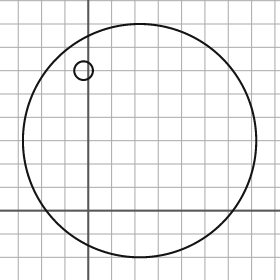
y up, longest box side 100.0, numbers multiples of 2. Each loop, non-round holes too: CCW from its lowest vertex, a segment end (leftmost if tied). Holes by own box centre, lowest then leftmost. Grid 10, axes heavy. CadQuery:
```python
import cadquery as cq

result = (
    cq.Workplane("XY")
    .moveTo(22.0, 30.0)
    .circle(50.0)
    .moveTo(-2.0, 60.0)
    .circle(4.0)
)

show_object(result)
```